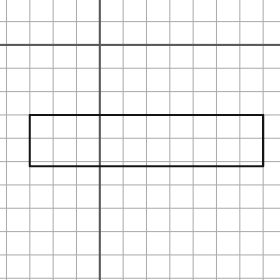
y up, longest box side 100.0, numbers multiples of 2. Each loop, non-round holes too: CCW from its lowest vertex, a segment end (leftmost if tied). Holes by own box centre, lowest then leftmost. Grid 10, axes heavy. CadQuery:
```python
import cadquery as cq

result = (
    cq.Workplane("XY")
    .moveTo(-30.0, -52.0)
    .lineTo(70.0, -52.0)
    .lineTo(70.0, -30.0)
    .lineTo(-30.0, -30.0)
    .close()
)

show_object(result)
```